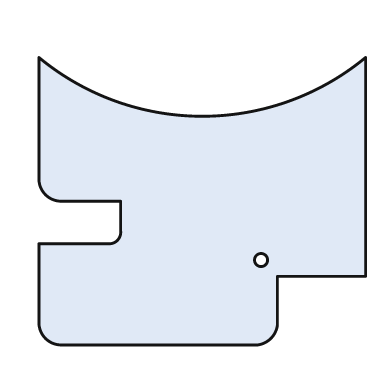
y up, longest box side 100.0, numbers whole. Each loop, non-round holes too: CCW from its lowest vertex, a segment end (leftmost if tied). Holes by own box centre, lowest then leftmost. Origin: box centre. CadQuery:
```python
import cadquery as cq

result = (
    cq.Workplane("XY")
    .moveTo(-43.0, -44.0)
    .lineTo(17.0, -44.0)
    .threePointArc((21.0, -42.0), (23.0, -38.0))
    .lineTo(23.0, -23.0)
    .lineTo(50.0, -23.0)
    .lineTo(50.0, 44.0)
    .threePointArc((0.0, 26.0), (-50.0, 44.0))
    .lineTo(-50.0, 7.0)
    .threePointArc((-48.0, 2.0), (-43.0, 0.0))
    .lineTo(-25.0, 0.0)
    .lineTo(-25.0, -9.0)
    .threePointArc((-26.0, -12.0), (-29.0, -13.0))
    .lineTo(-50.0, -13.0)
    .lineTo(-50.0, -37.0)
    .threePointArc((-48.0, -42.0), (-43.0, -44.0))
    .close()
    .moveTo(18.0, -18.0)
    .circle(2.0)
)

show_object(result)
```